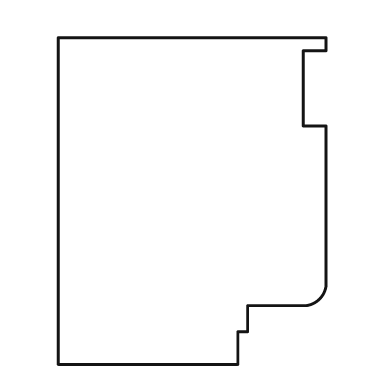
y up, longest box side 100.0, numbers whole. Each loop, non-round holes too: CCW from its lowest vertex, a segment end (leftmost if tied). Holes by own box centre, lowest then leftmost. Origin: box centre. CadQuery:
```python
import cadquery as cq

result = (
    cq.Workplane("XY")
    .moveTo(-41.0, -50.0)
    .lineTo(14.0, -50.0)
    .lineTo(14.0, -40.0)
    .lineTo(17.0, -40.0)
    .lineTo(17.0, -32.0)
    .lineTo(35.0, -32.0)
    .threePointArc((39.0, -30.0), (41.0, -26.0))
    .lineTo(41.0, 23.0)
    .lineTo(34.0, 23.0)
    .lineTo(34.0, 46.0)
    .lineTo(41.0, 46.0)
    .lineTo(41.0, 50.0)
    .lineTo(-41.0, 50.0)
    .close()
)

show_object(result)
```